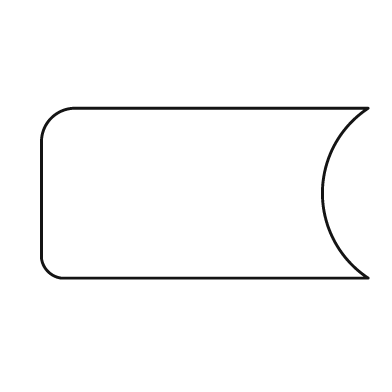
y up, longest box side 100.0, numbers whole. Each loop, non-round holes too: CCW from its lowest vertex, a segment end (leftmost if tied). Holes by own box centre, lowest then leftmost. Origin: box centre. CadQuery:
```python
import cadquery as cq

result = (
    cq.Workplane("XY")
    .moveTo(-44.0, -26.0)
    .lineTo(50.0, -26.0)
    .threePointArc((36.0, 0.0), (50.0, 26.0))
    .lineTo(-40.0, 26.0)
    .threePointArc((-47.0, 23.0), (-50.0, 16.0))
    .lineTo(-50.0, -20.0)
    .threePointArc((-48.0, -24.0), (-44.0, -26.0))
    .close()
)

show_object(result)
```